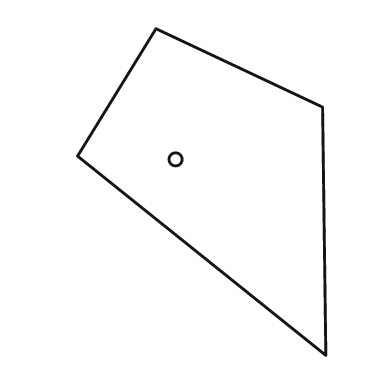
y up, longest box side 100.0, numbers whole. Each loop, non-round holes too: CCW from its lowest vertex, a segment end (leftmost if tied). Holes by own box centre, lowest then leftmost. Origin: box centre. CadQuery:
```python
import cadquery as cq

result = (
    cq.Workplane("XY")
    .moveTo(38.0, -50.0)
    .lineTo(37.0, 26.0)
    .lineTo(-14.0, 50.0)
    .lineTo(-38.0, 11.0)
    .close()
    .moveTo(-8.0, 10.0)
    .circle(2.0)
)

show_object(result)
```